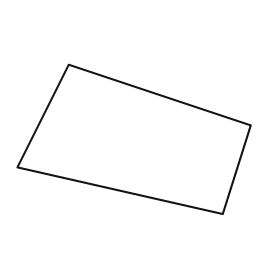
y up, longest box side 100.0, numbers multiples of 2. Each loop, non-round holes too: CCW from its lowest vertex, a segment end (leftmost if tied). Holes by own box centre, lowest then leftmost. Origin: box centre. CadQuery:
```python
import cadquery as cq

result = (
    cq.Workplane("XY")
    .moveTo(38.0, -32.0)
    .lineTo(50.0, 6.0)
    .lineTo(-28.0, 32.0)
    .lineTo(-50.0, -12.0)
    .close()
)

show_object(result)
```